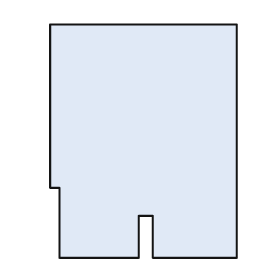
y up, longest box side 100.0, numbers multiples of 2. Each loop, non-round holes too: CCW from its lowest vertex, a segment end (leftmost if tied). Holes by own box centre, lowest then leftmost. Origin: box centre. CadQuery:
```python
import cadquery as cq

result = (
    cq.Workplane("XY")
    .moveTo(-36.0, -50.0)
    .lineTo(-2.0, -50.0)
    .lineTo(-2.0, -32.0)
    .lineTo(4.0, -32.0)
    .lineTo(4.0, -50.0)
    .lineTo(40.0, -50.0)
    .lineTo(40.0, 50.0)
    .lineTo(-40.0, 50.0)
    .lineTo(-40.0, -20.0)
    .lineTo(-36.0, -20.0)
    .close()
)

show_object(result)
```